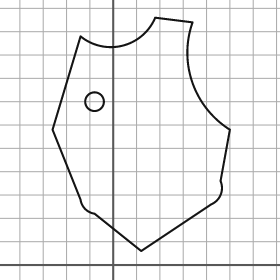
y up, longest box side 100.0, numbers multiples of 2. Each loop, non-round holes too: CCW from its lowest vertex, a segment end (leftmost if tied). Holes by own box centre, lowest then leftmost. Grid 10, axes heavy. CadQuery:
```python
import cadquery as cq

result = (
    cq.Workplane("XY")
    .moveTo(12.0, 6.0)
    .lineTo(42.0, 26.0)
    .threePointArc((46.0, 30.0), (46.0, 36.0))
    .lineTo(50.0, 58.0)
    .threePointArc((34.0, 78.0), (34.0, 104.0))
    .lineTo(18.0, 106.0)
    .threePointArc((4.0, 94.0), (-14.0, 98.0))
    .lineTo(-26.0, 58.0)
    .lineTo(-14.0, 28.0)
    .threePointArc((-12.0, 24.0), (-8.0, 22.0))
    .close()
    .moveTo(-8.0, 70.0)
    .circle(4.0)
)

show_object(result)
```